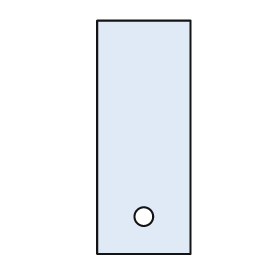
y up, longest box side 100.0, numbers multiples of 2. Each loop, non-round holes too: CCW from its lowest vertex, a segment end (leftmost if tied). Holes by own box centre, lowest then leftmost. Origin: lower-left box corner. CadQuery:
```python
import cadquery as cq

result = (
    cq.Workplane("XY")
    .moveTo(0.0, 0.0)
    .lineTo(40.0, 0.0)
    .lineTo(40.0, 100.0)
    .lineTo(0.0, 100.0)
    .close()
    .moveTo(20.0, 16.0)
    .circle(4.0)
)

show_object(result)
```